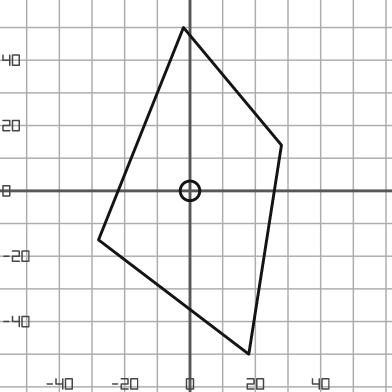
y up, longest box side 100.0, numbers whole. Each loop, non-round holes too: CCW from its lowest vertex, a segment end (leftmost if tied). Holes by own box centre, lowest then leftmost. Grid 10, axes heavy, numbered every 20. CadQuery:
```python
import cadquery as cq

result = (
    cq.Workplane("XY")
    .moveTo(18.0, -50.0)
    .lineTo(28.0, 14.0)
    .lineTo(-2.0, 50.0)
    .lineTo(-28.0, -15.0)
    .close()
    .moveTo(0.0, 0.0)
    .circle(3.0)
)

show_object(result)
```